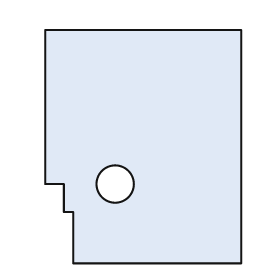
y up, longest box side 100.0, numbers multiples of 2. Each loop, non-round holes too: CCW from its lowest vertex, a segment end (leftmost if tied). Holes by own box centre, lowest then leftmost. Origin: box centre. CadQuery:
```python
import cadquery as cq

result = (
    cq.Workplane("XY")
    .moveTo(-30.0, -50.0)
    .lineTo(42.0, -50.0)
    .lineTo(42.0, 50.0)
    .lineTo(-42.0, 50.0)
    .lineTo(-42.0, -16.0)
    .lineTo(-34.0, -16.0)
    .lineTo(-34.0, -28.0)
    .lineTo(-30.0, -28.0)
    .close()
    .moveTo(-12.0, -16.0)
    .circle(8.0)
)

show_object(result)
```